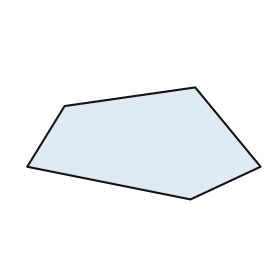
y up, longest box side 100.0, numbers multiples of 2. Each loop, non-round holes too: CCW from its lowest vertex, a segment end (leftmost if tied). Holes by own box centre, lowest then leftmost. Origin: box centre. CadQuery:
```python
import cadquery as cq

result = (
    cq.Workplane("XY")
    .moveTo(20.0, -24.0)
    .lineTo(50.0, -10.0)
    .lineTo(22.0, 24.0)
    .lineTo(-34.0, 16.0)
    .lineTo(-50.0, -10.0)
    .close()
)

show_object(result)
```